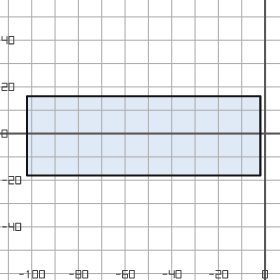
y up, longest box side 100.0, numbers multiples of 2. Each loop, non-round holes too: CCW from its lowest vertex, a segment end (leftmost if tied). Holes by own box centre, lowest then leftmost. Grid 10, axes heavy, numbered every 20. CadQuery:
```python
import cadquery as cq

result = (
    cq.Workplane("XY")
    .moveTo(-102.0, -18.0)
    .lineTo(-2.0, -18.0)
    .lineTo(-2.0, 16.0)
    .lineTo(-102.0, 16.0)
    .close()
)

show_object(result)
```